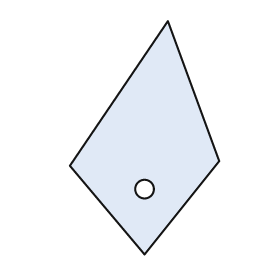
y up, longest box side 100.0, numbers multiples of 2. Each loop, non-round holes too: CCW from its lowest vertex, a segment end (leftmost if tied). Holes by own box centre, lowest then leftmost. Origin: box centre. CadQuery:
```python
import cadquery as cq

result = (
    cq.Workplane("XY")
    .moveTo(0.0, -50.0)
    .lineTo(32.0, -10.0)
    .lineTo(10.0, 50.0)
    .lineTo(-32.0, -12.0)
    .close()
    .moveTo(0.0, -22.0)
    .circle(4.0)
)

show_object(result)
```